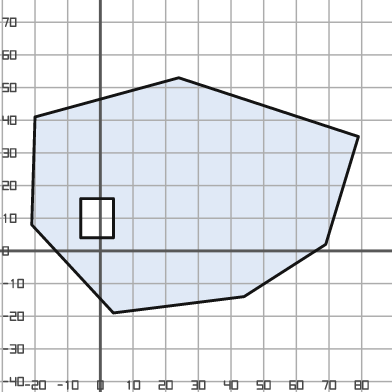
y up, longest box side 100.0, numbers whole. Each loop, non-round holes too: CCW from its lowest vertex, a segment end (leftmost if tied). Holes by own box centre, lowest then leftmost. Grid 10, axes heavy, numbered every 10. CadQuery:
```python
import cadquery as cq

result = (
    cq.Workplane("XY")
    .moveTo(4.0, -19.0)
    .lineTo(44.0, -14.0)
    .lineTo(69.0, 2.0)
    .lineTo(79.0, 35.0)
    .lineTo(24.0, 53.0)
    .lineTo(-20.0, 41.0)
    .lineTo(-21.0, 8.0)
    .close()
    .moveTo(-6.0, 4.0)
    .lineTo(4.0, 4.0)
    .lineTo(4.0, 16.0)
    .lineTo(-6.0, 16.0)
    .close()
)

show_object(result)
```